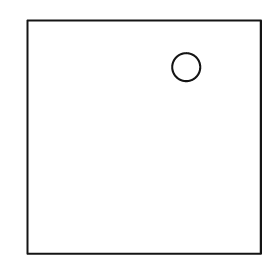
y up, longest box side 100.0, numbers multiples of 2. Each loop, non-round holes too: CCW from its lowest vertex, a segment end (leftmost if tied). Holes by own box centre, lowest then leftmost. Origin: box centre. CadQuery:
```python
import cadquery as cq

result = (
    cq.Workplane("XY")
    .moveTo(-50.0, -50.0)
    .lineTo(50.0, -50.0)
    .lineTo(50.0, 50.0)
    .lineTo(-50.0, 50.0)
    .close()
    .moveTo(18.0, 30.0)
    .circle(6.0)
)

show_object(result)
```